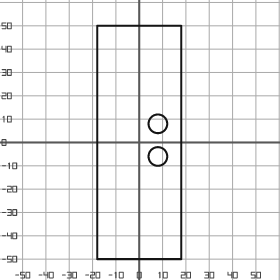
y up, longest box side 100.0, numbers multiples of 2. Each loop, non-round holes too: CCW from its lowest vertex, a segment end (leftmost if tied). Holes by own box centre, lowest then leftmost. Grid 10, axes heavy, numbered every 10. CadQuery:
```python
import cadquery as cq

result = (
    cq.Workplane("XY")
    .moveTo(-18.0, -50.0)
    .lineTo(18.0, -50.0)
    .lineTo(18.0, 50.0)
    .lineTo(-18.0, 50.0)
    .close()
    .moveTo(8.0, -6.0)
    .circle(4.0)
    .moveTo(8.0, 8.0)
    .circle(4.0)
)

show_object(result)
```